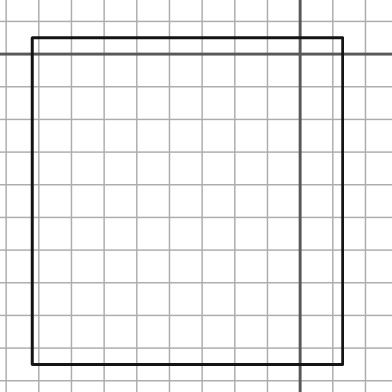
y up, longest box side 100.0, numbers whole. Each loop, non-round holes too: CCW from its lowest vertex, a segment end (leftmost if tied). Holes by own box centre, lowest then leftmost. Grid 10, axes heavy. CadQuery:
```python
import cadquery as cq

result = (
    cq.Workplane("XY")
    .moveTo(-82.0, -95.0)
    .lineTo(13.0, -95.0)
    .lineTo(13.0, 5.0)
    .lineTo(-82.0, 5.0)
    .close()
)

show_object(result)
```